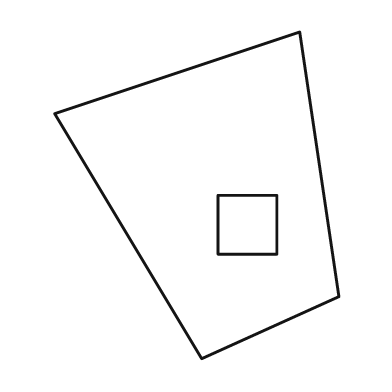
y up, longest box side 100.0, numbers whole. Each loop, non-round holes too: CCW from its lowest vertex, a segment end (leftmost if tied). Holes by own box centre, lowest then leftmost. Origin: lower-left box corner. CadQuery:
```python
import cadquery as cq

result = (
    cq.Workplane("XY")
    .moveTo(45.0, 0.0)
    .lineTo(87.0, 19.0)
    .lineTo(75.0, 100.0)
    .lineTo(0.0, 75.0)
    .close()
    .moveTo(50.0, 32.0)
    .lineTo(68.0, 32.0)
    .lineTo(68.0, 50.0)
    .lineTo(50.0, 50.0)
    .close()
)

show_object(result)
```